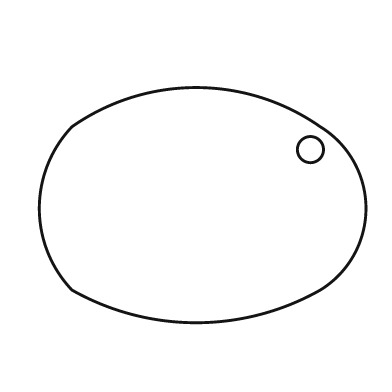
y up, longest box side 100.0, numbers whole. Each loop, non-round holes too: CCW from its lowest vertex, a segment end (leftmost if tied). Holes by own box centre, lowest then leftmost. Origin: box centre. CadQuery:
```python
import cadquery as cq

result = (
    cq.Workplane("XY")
    .moveTo(-40.0, -26.0)
    .threePointArc((-2.0, -36.0), (36.0, -26.0))
    .threePointArc((50.0, -1.0), (36.0, 24.0))
    .threePointArc((-2.0, 36.0), (-40.0, 24.0))
    .threePointArc((-50.0, -1.0), (-40.0, -26.0))
    .close()
    .moveTo(33.0, 17.0)
    .circle(4.0)
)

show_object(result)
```